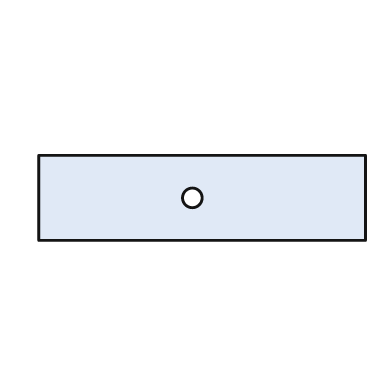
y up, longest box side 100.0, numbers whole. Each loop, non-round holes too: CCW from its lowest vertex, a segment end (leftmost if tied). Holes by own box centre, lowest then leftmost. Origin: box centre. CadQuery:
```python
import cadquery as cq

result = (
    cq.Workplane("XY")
    .moveTo(-50.0, -13.0)
    .lineTo(50.0, -13.0)
    .lineTo(50.0, 13.0)
    .lineTo(-50.0, 13.0)
    .close()
    .moveTo(-3.0, 0.0)
    .circle(3.0)
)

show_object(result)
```